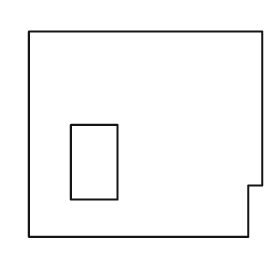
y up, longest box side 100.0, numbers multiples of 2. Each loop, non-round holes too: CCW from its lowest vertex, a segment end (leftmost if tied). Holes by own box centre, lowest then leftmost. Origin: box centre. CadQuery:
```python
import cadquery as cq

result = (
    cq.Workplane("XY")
    .moveTo(-50.0, -44.0)
    .lineTo(44.0, -44.0)
    .lineTo(44.0, -22.0)
    .lineTo(50.0, -22.0)
    .lineTo(50.0, 44.0)
    .lineTo(-50.0, 44.0)
    .close()
    .moveTo(-32.0, -28.0)
    .lineTo(-12.0, -28.0)
    .lineTo(-12.0, 4.0)
    .lineTo(-32.0, 4.0)
    .close()
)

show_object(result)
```